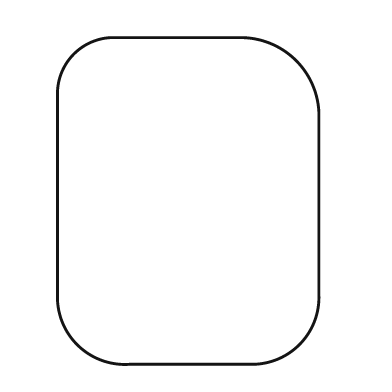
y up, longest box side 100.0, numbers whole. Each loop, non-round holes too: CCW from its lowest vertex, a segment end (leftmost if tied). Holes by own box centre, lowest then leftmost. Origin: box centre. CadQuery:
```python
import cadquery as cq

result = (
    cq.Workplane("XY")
    .moveTo(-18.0, -50.0)
    .lineTo(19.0, -50.0)
    .threePointArc((34.0, -44.0), (40.0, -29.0))
    .lineTo(40.0, 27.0)
    .threePointArc((33.0, 43.0), (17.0, 50.0))
    .lineTo(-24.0, 50.0)
    .threePointArc((-35.0, 45.0), (-40.0, 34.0))
    .lineTo(-40.0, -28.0)
    .threePointArc((-34.0, -44.0), (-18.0, -50.0))
    .close()
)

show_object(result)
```